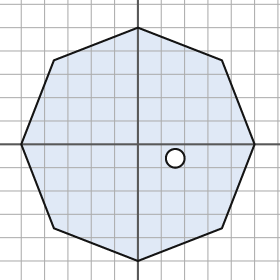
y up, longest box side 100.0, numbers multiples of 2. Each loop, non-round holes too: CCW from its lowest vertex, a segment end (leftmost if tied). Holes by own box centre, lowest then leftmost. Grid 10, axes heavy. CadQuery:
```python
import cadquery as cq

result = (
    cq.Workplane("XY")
    .moveTo(0.0, -50.0)
    .lineTo(36.0, -36.0)
    .lineTo(50.0, 0.0)
    .lineTo(36.0, 36.0)
    .lineTo(0.0, 50.0)
    .lineTo(-36.0, 36.0)
    .lineTo(-50.0, 0.0)
    .lineTo(-36.0, -36.0)
    .close()
    .moveTo(16.0, -6.0)
    .circle(4.0)
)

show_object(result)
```